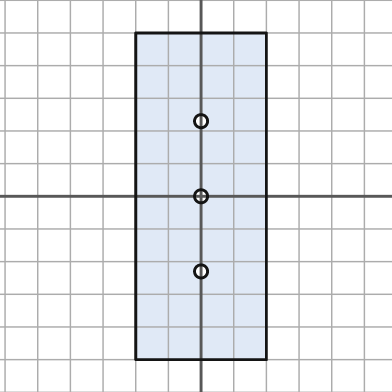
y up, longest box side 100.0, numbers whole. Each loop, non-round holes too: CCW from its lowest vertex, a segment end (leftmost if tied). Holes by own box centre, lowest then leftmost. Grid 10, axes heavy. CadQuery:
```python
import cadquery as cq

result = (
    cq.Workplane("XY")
    .moveTo(-20.0, -50.0)
    .lineTo(20.0, -50.0)
    .lineTo(20.0, 50.0)
    .lineTo(-20.0, 50.0)
    .close()
    .moveTo(0.0, -23.0)
    .circle(2.0)
    .moveTo(0.0, 0.0)
    .circle(2.0)
    .moveTo(0.0, 23.0)
    .circle(2.0)
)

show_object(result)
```